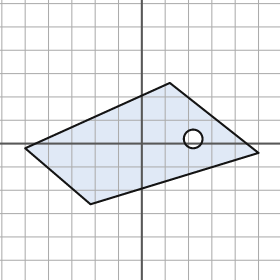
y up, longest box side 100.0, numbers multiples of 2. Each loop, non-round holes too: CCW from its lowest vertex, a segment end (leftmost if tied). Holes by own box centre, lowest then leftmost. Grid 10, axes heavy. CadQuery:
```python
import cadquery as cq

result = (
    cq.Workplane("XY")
    .moveTo(-22.0, -26.0)
    .lineTo(50.0, -4.0)
    .lineTo(12.0, 26.0)
    .lineTo(-50.0, -2.0)
    .close()
    .moveTo(22.0, 2.0)
    .circle(4.0)
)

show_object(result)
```